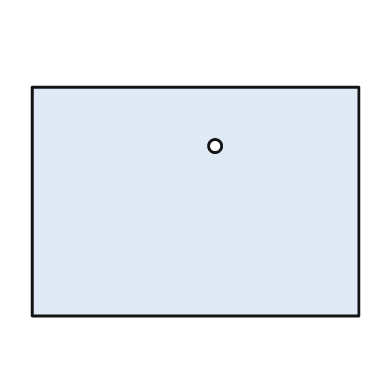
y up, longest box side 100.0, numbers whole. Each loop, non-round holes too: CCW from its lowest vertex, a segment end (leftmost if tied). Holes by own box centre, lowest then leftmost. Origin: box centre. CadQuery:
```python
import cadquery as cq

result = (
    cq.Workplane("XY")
    .moveTo(-50.0, -35.0)
    .lineTo(50.0, -35.0)
    .lineTo(50.0, 35.0)
    .lineTo(-50.0, 35.0)
    .close()
    .moveTo(6.0, 17.0)
    .circle(2.0)
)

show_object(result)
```